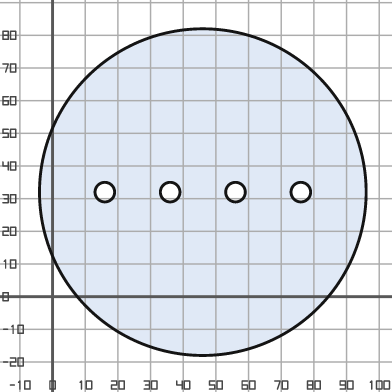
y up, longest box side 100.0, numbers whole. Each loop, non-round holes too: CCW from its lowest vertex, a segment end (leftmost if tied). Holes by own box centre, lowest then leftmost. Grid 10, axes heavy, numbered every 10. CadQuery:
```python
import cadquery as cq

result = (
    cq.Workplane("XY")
    .moveTo(46.0, 32.0)
    .circle(50.0)
    .moveTo(16.0, 32.0)
    .circle(3.0)
    .moveTo(36.0, 32.0)
    .circle(3.0)
    .moveTo(56.0, 32.0)
    .circle(3.0)
    .moveTo(76.0, 32.0)
    .circle(3.0)
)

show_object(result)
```